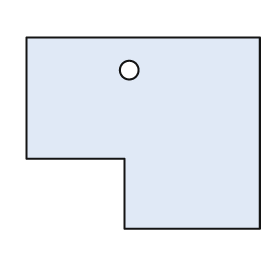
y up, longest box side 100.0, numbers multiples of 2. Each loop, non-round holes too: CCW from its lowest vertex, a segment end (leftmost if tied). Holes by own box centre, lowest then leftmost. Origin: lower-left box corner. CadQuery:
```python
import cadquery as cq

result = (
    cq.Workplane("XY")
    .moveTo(42.0, 0.0)
    .lineTo(100.0, 0.0)
    .lineTo(100.0, 82.0)
    .lineTo(0.0, 82.0)
    .lineTo(0.0, 30.0)
    .lineTo(42.0, 30.0)
    .close()
    .moveTo(44.0, 68.0)
    .circle(4.0)
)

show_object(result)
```